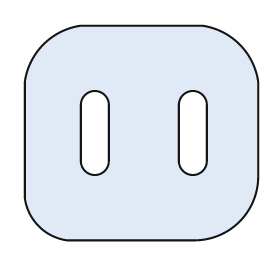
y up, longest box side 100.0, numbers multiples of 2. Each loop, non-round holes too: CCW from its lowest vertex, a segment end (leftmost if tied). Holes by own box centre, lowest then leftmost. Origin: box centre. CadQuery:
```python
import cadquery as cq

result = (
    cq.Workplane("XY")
    .moveTo(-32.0, -46.0)
    .lineTo(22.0, -46.0)
    .threePointArc((42.0, -38.0), (50.0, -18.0))
    .lineTo(50.0, 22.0)
    .threePointArc((42.0, 38.0), (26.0, 46.0))
    .lineTo(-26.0, 46.0)
    .threePointArc((-42.0, 38.0), (-50.0, 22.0))
    .lineTo(-50.0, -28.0)
    .threePointArc((-44.0, -40.0), (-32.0, -46.0))
    .close()
    .moveTo(-26.0, -12.0)
    .threePointArc((-20.0, -18.0), (-14.0, -12.0))
    .lineTo(-14.0, 12.0)
    .threePointArc((-20.0, 18.0), (-26.0, 12.0))
    .close()
    .moveTo(16.0, -12.0)
    .threePointArc((22.0, -18.0), (28.0, -12.0))
    .lineTo(28.0, 12.0)
    .threePointArc((22.0, 18.0), (16.0, 12.0))
    .close()
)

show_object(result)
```